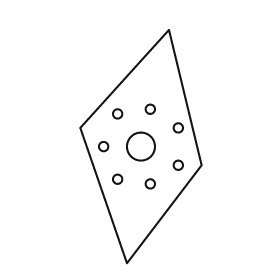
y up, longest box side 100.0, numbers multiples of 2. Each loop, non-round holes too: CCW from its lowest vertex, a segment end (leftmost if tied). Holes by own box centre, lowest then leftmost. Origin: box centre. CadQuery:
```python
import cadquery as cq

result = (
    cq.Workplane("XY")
    .moveTo(-6.0, -50.0)
    .lineTo(26.0, -8.0)
    .lineTo(12.0, 50.0)
    .lineTo(-26.0, 8.0)
    .close()
    .moveTo(4.0, -16.0)
    .circle(2.0)
    .moveTo(-10.0, -14.0)
    .circle(2.0)
    .moveTo(16.0, -8.0)
    .circle(2.0)
    .moveTo(-16.0, 0.0)
    .circle(2.0)
    .moveTo(0.0, 0.0)
    .circle(6.0)
    .moveTo(16.0, 8.0)
    .circle(2.0)
    .moveTo(-10.0, 14.0)
    .circle(2.0)
    .moveTo(4.0, 16.0)
    .circle(2.0)
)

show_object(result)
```